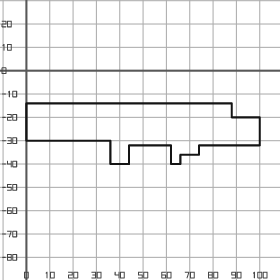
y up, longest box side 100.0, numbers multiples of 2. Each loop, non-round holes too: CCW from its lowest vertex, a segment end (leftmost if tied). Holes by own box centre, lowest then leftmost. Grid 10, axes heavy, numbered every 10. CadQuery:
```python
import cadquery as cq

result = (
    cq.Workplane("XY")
    .moveTo(36.0, -40.0)
    .lineTo(44.0, -40.0)
    .lineTo(44.0, -32.0)
    .lineTo(62.0, -32.0)
    .lineTo(62.0, -40.0)
    .lineTo(66.0, -40.0)
    .lineTo(66.0, -36.0)
    .lineTo(74.0, -36.0)
    .lineTo(74.0, -32.0)
    .lineTo(100.0, -32.0)
    .lineTo(100.0, -20.0)
    .lineTo(88.0, -20.0)
    .lineTo(88.0, -14.0)
    .lineTo(0.0, -14.0)
    .lineTo(0.0, -30.0)
    .lineTo(36.0, -30.0)
    .close()
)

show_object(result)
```